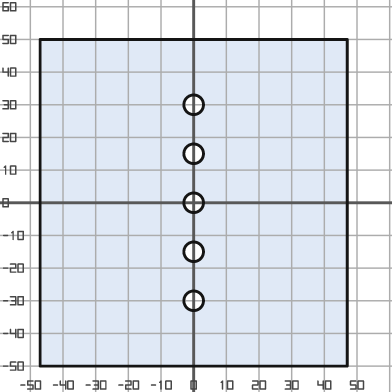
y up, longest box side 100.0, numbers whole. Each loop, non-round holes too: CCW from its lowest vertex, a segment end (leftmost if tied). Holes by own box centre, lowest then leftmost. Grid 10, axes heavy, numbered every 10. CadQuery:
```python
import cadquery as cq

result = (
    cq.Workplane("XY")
    .moveTo(-47.0, -50.0)
    .lineTo(47.0, -50.0)
    .lineTo(47.0, 50.0)
    .lineTo(-47.0, 50.0)
    .close()
    .moveTo(0.0, -30.0)
    .circle(3.0)
    .moveTo(0.0, -15.0)
    .circle(3.0)
    .moveTo(0.0, 0.0)
    .circle(3.0)
    .moveTo(0.0, 15.0)
    .circle(3.0)
    .moveTo(0.0, 30.0)
    .circle(3.0)
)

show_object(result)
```